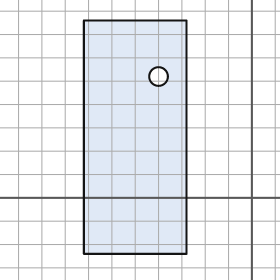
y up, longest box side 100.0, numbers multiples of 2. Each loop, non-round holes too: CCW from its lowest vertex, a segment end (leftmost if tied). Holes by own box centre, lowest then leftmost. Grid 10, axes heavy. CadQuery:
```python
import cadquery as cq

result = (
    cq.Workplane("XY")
    .moveTo(-72.0, -24.0)
    .lineTo(-28.0, -24.0)
    .lineTo(-28.0, 76.0)
    .lineTo(-72.0, 76.0)
    .close()
    .moveTo(-40.0, 52.0)
    .circle(4.0)
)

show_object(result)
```